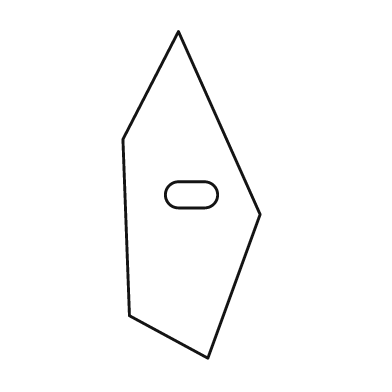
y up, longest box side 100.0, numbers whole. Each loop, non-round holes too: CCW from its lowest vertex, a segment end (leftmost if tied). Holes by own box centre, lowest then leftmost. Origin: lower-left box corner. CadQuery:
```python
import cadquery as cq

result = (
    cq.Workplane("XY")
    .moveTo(26.0, 0.0)
    .lineTo(42.0, 44.0)
    .lineTo(17.0, 100.0)
    .lineTo(0.0, 67.0)
    .lineTo(2.0, 13.0)
    .close()
    .moveTo(17.0, 46.0)
    .lineTo(25.0, 46.0)
    .threePointArc((29.0, 50.0), (25.0, 54.0))
    .lineTo(17.0, 54.0)
    .threePointArc((13.0, 50.0), (17.0, 46.0))
    .close()
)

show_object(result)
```